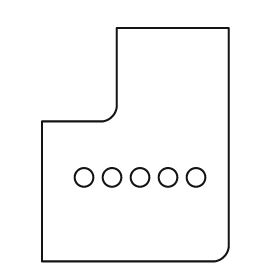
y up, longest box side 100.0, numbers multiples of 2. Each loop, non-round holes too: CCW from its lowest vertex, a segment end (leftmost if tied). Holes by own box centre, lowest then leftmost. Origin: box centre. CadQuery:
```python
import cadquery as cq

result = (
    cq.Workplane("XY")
    .moveTo(-40.0, -50.0)
    .lineTo(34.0, -50.0)
    .threePointArc((38.0, -48.0), (40.0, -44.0))
    .lineTo(40.0, 50.0)
    .lineTo(-8.0, 50.0)
    .lineTo(-8.0, 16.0)
    .threePointArc((-10.0, 12.0), (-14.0, 10.0))
    .lineTo(-40.0, 10.0)
    .close()
    .moveTo(-22.0, -14.0)
    .circle(4.0)
    .moveTo(-10.0, -14.0)
    .circle(4.0)
    .moveTo(2.0, -14.0)
    .circle(4.0)
    .moveTo(14.0, -14.0)
    .circle(4.0)
    .moveTo(26.0, -14.0)
    .circle(4.0)
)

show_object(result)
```